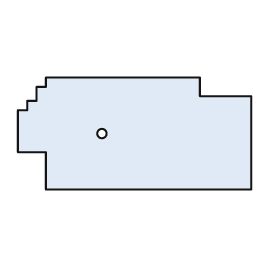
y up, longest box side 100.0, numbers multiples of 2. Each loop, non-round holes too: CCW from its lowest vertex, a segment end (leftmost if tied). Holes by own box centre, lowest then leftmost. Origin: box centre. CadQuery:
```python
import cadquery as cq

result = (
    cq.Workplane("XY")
    .moveTo(-38.0, -24.0)
    .lineTo(50.0, -24.0)
    .lineTo(50.0, 16.0)
    .lineTo(28.0, 16.0)
    .lineTo(28.0, 24.0)
    .lineTo(-38.0, 24.0)
    .lineTo(-38.0, 20.0)
    .lineTo(-42.0, 20.0)
    .lineTo(-42.0, 14.0)
    .lineTo(-46.0, 14.0)
    .lineTo(-46.0, 10.0)
    .lineTo(-50.0, 10.0)
    .lineTo(-50.0, -8.0)
    .lineTo(-38.0, -8.0)
    .close()
    .moveTo(-14.0, 0.0)
    .circle(2.0)
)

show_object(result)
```